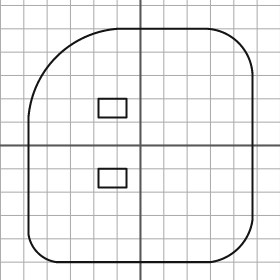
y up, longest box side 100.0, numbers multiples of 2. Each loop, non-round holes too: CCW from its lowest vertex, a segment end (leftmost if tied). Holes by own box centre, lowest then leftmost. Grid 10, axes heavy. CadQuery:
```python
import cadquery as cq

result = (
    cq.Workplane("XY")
    .moveTo(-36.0, -50.0)
    .lineTo(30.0, -50.0)
    .threePointArc((42.0, -44.0), (48.0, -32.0))
    .lineTo(48.0, 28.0)
    .threePointArc((42.0, 44.0), (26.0, 50.0))
    .lineTo(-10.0, 50.0)
    .threePointArc((-36.0, 38.0), (-48.0, 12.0))
    .lineTo(-48.0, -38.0)
    .threePointArc((-44.0, -46.0), (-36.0, -50.0))
    .close()
    .moveTo(-18.0, -18.0)
    .lineTo(-6.0, -18.0)
    .lineTo(-6.0, -10.0)
    .lineTo(-18.0, -10.0)
    .close()
    .moveTo(-18.0, 12.0)
    .lineTo(-6.0, 12.0)
    .lineTo(-6.0, 20.0)
    .lineTo(-18.0, 20.0)
    .close()
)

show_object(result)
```